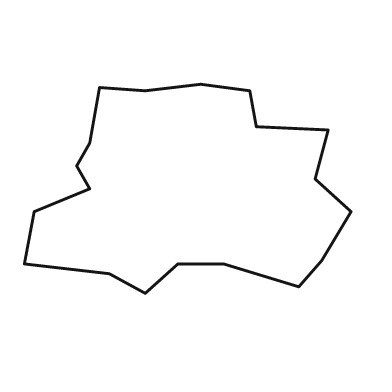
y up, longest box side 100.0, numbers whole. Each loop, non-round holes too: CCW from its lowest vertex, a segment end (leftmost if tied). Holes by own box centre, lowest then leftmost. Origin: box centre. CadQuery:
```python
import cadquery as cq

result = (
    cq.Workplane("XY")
    .moveTo(-13.0, -32.0)
    .lineTo(-3.0, -23.0)
    .lineTo(11.0, -23.0)
    .lineTo(34.0, -30.0)
    .lineTo(41.0, -22.0)
    .lineTo(50.0, -7.0)
    .lineTo(39.0, 3.0)
    .lineTo(43.0, 18.0)
    .lineTo(21.0, 19.0)
    .lineTo(19.0, 30.0)
    .lineTo(4.0, 32.0)
    .lineTo(-13.0, 30.0)
    .lineTo(-27.0, 31.0)
    .lineTo(-30.0, 14.0)
    .lineTo(-34.0, 7.0)
    .lineTo(-30.0, 0.0)
    .lineTo(-47.0, -7.0)
    .lineTo(-50.0, -23.0)
    .lineTo(-24.0, -26.0)
    .close()
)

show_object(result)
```